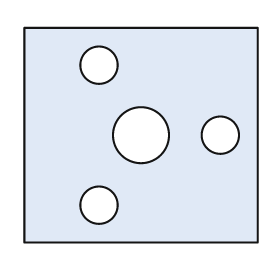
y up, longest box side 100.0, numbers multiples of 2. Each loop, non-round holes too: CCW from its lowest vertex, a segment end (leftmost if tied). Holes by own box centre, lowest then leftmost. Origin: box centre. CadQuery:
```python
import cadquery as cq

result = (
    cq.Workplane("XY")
    .moveTo(-50.0, -46.0)
    .lineTo(50.0, -46.0)
    .lineTo(50.0, 46.0)
    .lineTo(-50.0, 46.0)
    .close()
    .moveTo(-18.0, -30.0)
    .circle(8.0)
    .moveTo(0.0, 0.0)
    .circle(12.0)
    .moveTo(34.0, 0.0)
    .circle(8.0)
    .moveTo(-18.0, 30.0)
    .circle(8.0)
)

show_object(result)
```